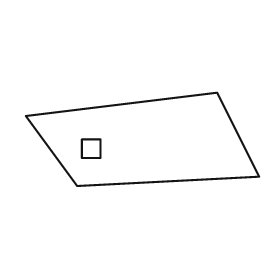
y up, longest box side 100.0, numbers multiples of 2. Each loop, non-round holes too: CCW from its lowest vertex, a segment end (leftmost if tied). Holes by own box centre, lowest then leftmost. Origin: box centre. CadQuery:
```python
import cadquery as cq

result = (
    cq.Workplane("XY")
    .moveTo(-28.0, -20.0)
    .lineTo(50.0, -16.0)
    .lineTo(32.0, 20.0)
    .lineTo(-50.0, 10.0)
    .close()
    .moveTo(-26.0, -8.0)
    .lineTo(-18.0, -8.0)
    .lineTo(-18.0, 0.0)
    .lineTo(-26.0, 0.0)
    .close()
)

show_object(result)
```